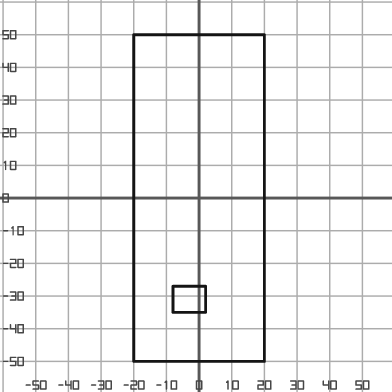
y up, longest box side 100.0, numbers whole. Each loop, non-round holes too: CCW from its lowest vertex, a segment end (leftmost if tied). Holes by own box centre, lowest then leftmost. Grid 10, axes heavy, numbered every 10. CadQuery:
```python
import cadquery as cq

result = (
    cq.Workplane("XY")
    .moveTo(-20.0, -50.0)
    .lineTo(20.0, -50.0)
    .lineTo(20.0, 50.0)
    .lineTo(-20.0, 50.0)
    .close()
    .moveTo(-8.0, -35.0)
    .lineTo(2.0, -35.0)
    .lineTo(2.0, -27.0)
    .lineTo(-8.0, -27.0)
    .close()
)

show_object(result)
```